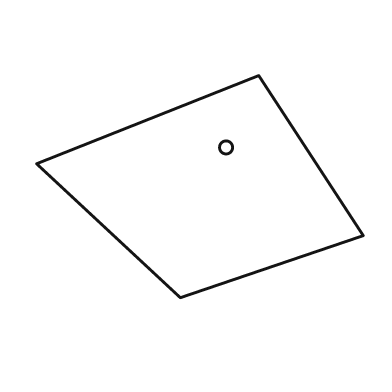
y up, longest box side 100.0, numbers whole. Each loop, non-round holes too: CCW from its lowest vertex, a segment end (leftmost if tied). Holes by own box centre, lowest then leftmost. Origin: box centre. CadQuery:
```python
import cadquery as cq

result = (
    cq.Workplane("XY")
    .moveTo(-6.0, -34.0)
    .lineTo(50.0, -15.0)
    .lineTo(18.0, 34.0)
    .lineTo(-50.0, 7.0)
    .close()
    .moveTo(8.0, 12.0)
    .circle(2.0)
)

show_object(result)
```